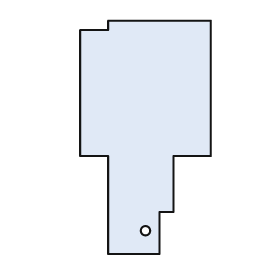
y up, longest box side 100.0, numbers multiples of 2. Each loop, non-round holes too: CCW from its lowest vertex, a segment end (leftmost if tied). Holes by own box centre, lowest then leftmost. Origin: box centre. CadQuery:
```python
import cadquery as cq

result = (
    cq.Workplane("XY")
    .moveTo(-16.0, -50.0)
    .lineTo(6.0, -50.0)
    .lineTo(6.0, -32.0)
    .lineTo(12.0, -32.0)
    .lineTo(12.0, -8.0)
    .lineTo(28.0, -8.0)
    .lineTo(28.0, 50.0)
    .lineTo(-16.0, 50.0)
    .lineTo(-16.0, 46.0)
    .lineTo(-28.0, 46.0)
    .lineTo(-28.0, -8.0)
    .lineTo(-16.0, -8.0)
    .close()
    .moveTo(0.0, -40.0)
    .circle(2.0)
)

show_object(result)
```